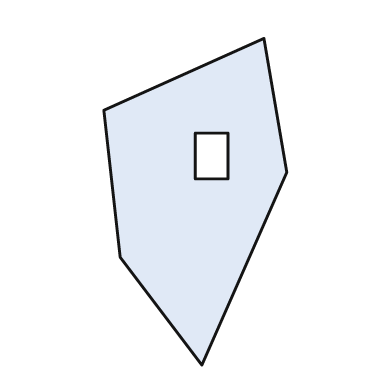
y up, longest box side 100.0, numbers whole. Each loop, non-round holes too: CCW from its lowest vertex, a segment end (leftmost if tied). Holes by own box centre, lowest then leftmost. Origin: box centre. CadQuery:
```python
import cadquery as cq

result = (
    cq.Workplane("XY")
    .moveTo(2.0, -50.0)
    .lineTo(28.0, 9.0)
    .lineTo(21.0, 50.0)
    .lineTo(-28.0, 28.0)
    .lineTo(-23.0, -17.0)
    .close()
    .moveTo(0.0, 7.0)
    .lineTo(10.0, 7.0)
    .lineTo(10.0, 21.0)
    .lineTo(0.0, 21.0)
    .close()
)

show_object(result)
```